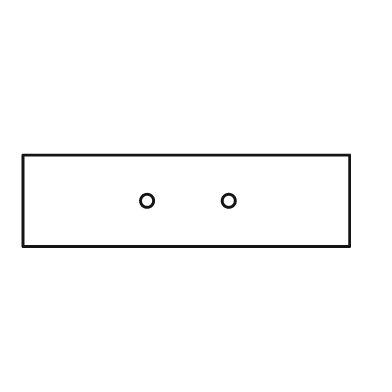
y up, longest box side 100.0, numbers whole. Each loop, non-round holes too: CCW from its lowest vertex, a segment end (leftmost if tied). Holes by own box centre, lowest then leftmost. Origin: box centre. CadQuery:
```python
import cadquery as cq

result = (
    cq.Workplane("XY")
    .moveTo(-50.0, -14.0)
    .lineTo(50.0, -14.0)
    .lineTo(50.0, 14.0)
    .lineTo(-50.0, 14.0)
    .close()
    .moveTo(-12.0, 0.0)
    .circle(2.0)
    .moveTo(13.0, 0.0)
    .circle(2.0)
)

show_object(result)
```